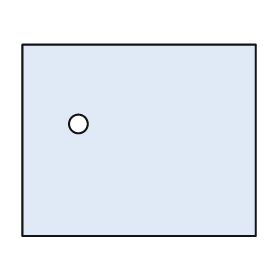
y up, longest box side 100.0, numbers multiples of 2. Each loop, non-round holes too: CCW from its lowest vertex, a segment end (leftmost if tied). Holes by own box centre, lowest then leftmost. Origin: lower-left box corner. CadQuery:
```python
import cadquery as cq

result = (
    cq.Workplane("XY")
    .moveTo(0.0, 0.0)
    .lineTo(100.0, 0.0)
    .lineTo(100.0, 82.0)
    .lineTo(0.0, 82.0)
    .close()
    .moveTo(24.0, 48.0)
    .circle(4.0)
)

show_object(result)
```